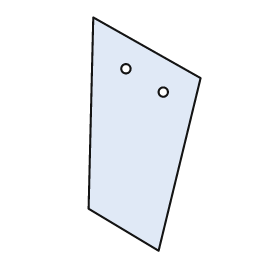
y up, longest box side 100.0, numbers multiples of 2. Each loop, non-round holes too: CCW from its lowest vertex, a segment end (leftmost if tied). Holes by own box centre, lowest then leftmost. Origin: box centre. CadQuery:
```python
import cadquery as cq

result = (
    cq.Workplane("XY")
    .moveTo(6.0, -50.0)
    .lineTo(24.0, 24.0)
    .lineTo(-22.0, 50.0)
    .lineTo(-24.0, -32.0)
    .close()
    .moveTo(8.0, 18.0)
    .circle(2.0)
    .moveTo(-8.0, 28.0)
    .circle(2.0)
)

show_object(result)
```